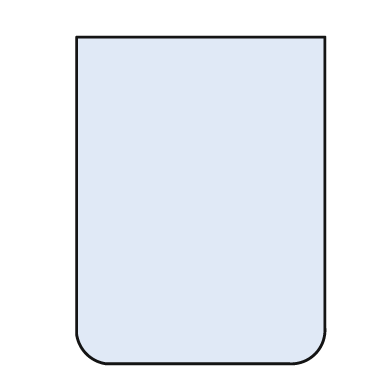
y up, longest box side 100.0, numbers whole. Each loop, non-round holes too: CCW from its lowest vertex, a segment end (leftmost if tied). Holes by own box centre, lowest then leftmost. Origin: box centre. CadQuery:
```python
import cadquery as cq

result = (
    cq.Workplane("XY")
    .moveTo(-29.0, -50.0)
    .lineTo(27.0, -50.0)
    .threePointArc((35.0, -47.0), (38.0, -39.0))
    .lineTo(38.0, 50.0)
    .lineTo(-38.0, 50.0)
    .lineTo(-38.0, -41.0)
    .threePointArc((-35.0, -47.0), (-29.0, -50.0))
    .close()
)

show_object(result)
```